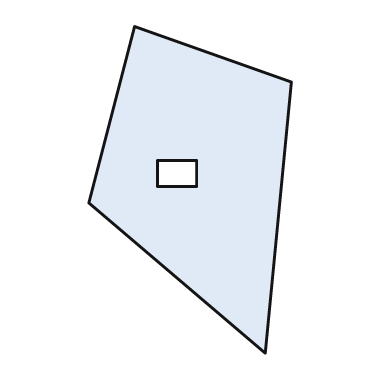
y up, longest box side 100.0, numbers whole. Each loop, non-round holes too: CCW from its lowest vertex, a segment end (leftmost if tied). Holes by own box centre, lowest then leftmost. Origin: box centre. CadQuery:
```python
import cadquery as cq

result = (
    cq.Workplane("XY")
    .moveTo(23.0, -50.0)
    .lineTo(31.0, 33.0)
    .lineTo(-17.0, 50.0)
    .lineTo(-31.0, -4.0)
    .close()
    .moveTo(-10.0, 1.0)
    .lineTo(2.0, 1.0)
    .lineTo(2.0, 9.0)
    .lineTo(-10.0, 9.0)
    .close()
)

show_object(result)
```